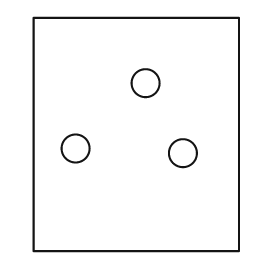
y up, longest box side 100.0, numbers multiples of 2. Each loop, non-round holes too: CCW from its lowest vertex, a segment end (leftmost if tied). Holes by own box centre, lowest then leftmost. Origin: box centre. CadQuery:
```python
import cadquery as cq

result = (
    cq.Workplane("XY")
    .moveTo(-44.0, -50.0)
    .lineTo(44.0, -50.0)
    .lineTo(44.0, 50.0)
    .lineTo(-44.0, 50.0)
    .close()
    .moveTo(20.0, -8.0)
    .circle(6.0)
    .moveTo(-26.0, -6.0)
    .circle(6.0)
    .moveTo(4.0, 22.0)
    .circle(6.0)
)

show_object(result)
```